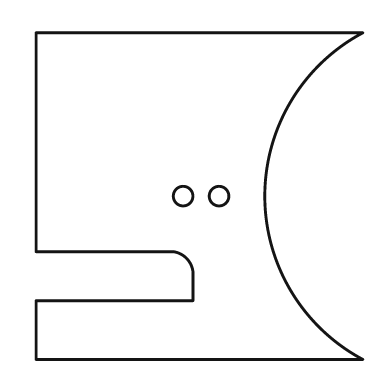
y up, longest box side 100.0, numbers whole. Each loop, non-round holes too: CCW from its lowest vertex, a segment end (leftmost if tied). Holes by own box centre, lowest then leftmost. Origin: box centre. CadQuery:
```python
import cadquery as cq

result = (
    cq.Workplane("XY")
    .moveTo(-50.0, -50.0)
    .lineTo(50.0, -50.0)
    .threePointArc((20.0, 0.0), (50.0, 50.0))
    .lineTo(-50.0, 50.0)
    .lineTo(-50.0, -17.0)
    .lineTo(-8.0, -17.0)
    .threePointArc((-4.0, -19.0), (-2.0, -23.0))
    .lineTo(-2.0, -32.0)
    .lineTo(-50.0, -32.0)
    .close()
    .moveTo(-5.0, 0.0)
    .circle(3.0)
    .moveTo(6.0, 0.0)
    .circle(3.0)
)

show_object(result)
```